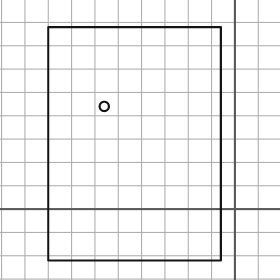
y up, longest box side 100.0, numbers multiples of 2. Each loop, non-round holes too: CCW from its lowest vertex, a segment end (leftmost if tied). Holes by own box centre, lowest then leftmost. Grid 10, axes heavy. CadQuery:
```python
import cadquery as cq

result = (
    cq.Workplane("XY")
    .moveTo(-80.0, -22.0)
    .lineTo(-6.0, -22.0)
    .lineTo(-6.0, 78.0)
    .lineTo(-80.0, 78.0)
    .close()
    .moveTo(-56.0, 44.0)
    .circle(2.0)
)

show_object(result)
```